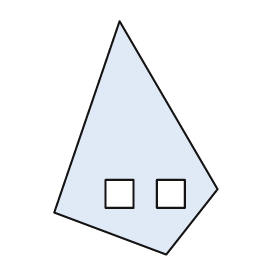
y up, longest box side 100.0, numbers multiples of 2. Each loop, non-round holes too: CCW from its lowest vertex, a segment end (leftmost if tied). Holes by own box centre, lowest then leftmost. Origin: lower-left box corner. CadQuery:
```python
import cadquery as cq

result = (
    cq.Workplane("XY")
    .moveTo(48.0, 0.0)
    .lineTo(70.0, 28.0)
    .lineTo(28.0, 100.0)
    .lineTo(0.0, 18.0)
    .close()
    .moveTo(22.0, 20.0)
    .lineTo(34.0, 20.0)
    .lineTo(34.0, 32.0)
    .lineTo(22.0, 32.0)
    .close()
    .moveTo(44.0, 20.0)
    .lineTo(56.0, 20.0)
    .lineTo(56.0, 32.0)
    .lineTo(44.0, 32.0)
    .close()
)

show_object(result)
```